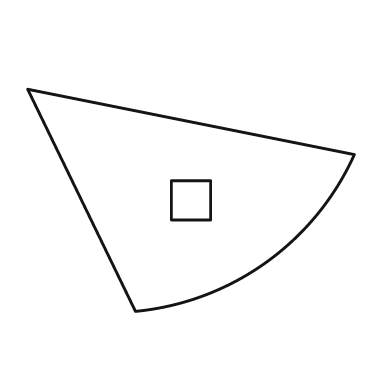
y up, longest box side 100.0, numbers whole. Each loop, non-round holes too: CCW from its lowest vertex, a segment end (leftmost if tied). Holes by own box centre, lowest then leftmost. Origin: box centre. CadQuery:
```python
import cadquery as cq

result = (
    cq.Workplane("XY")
    .moveTo(-17.0, -34.0)
    .threePointArc((23.0, -19.0), (50.0, 14.0))
    .lineTo(-50.0, 34.0)
    .close()
    .moveTo(-6.0, -6.0)
    .lineTo(6.0, -6.0)
    .lineTo(6.0, 6.0)
    .lineTo(-6.0, 6.0)
    .close()
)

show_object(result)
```